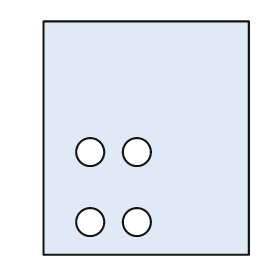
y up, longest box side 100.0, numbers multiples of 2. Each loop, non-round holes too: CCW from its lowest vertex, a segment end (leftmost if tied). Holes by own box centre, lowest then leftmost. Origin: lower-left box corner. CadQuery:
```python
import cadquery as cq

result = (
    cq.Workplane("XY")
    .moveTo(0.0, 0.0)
    .lineTo(88.0, 0.0)
    .lineTo(88.0, 100.0)
    .lineTo(0.0, 100.0)
    .close()
    .moveTo(20.0, 14.0)
    .circle(6.0)
    .moveTo(40.0, 14.0)
    .circle(6.0)
    .moveTo(20.0, 44.0)
    .circle(6.0)
    .moveTo(40.0, 44.0)
    .circle(6.0)
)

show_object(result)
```